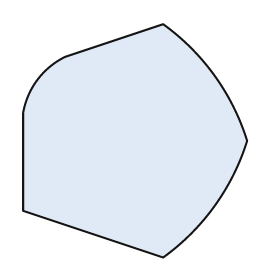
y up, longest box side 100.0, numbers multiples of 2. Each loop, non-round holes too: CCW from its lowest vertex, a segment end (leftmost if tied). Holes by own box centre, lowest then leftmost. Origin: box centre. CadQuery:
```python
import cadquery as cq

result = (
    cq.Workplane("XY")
    .moveTo(12.0, -50.0)
    .threePointArc((34.0, -28.0), (48.0, 0.0))
    .threePointArc((34.0, 28.0), (12.0, 50.0))
    .lineTo(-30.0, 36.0)
    .threePointArc((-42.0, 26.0), (-48.0, 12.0))
    .lineTo(-48.0, -30.0)
    .close()
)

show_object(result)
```